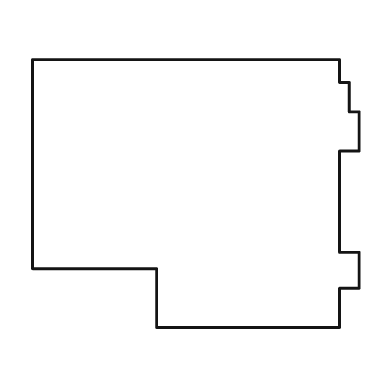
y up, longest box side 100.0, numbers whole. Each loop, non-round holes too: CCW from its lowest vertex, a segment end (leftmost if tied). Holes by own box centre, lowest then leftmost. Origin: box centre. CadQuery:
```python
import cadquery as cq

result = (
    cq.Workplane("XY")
    .moveTo(-12.0, -41.0)
    .lineTo(44.0, -41.0)
    .lineTo(44.0, -29.0)
    .lineTo(50.0, -29.0)
    .lineTo(50.0, -18.0)
    .lineTo(44.0, -18.0)
    .lineTo(44.0, 13.0)
    .lineTo(50.0, 13.0)
    .lineTo(50.0, 25.0)
    .lineTo(47.0, 25.0)
    .lineTo(47.0, 34.0)
    .lineTo(44.0, 34.0)
    .lineTo(44.0, 41.0)
    .lineTo(-50.0, 41.0)
    .lineTo(-50.0, -23.0)
    .lineTo(-12.0, -23.0)
    .close()
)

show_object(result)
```